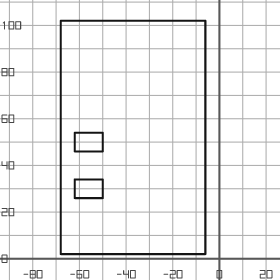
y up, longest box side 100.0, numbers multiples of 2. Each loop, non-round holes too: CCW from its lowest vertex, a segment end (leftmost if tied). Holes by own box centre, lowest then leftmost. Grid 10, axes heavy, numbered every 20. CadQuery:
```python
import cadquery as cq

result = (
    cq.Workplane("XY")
    .moveTo(-68.0, 2.0)
    .lineTo(-6.0, 2.0)
    .lineTo(-6.0, 102.0)
    .lineTo(-68.0, 102.0)
    .close()
    .moveTo(-62.0, 26.0)
    .lineTo(-50.0, 26.0)
    .lineTo(-50.0, 34.0)
    .lineTo(-62.0, 34.0)
    .close()
    .moveTo(-62.0, 46.0)
    .lineTo(-50.0, 46.0)
    .lineTo(-50.0, 54.0)
    .lineTo(-62.0, 54.0)
    .close()
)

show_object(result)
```